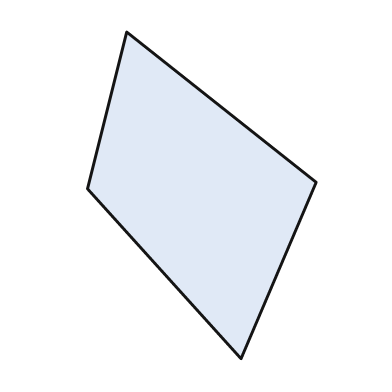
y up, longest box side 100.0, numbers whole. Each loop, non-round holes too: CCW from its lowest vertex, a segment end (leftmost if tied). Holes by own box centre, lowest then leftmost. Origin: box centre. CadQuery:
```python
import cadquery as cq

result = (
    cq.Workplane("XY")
    .moveTo(12.0, -50.0)
    .lineTo(35.0, 4.0)
    .lineTo(-23.0, 50.0)
    .lineTo(-35.0, 2.0)
    .close()
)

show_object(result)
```